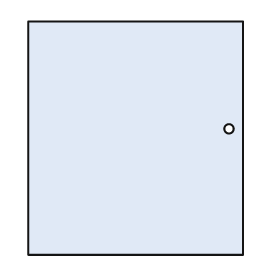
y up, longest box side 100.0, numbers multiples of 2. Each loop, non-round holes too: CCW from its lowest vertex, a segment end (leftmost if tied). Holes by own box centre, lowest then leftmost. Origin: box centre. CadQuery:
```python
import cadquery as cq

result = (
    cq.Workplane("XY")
    .moveTo(-46.0, -50.0)
    .lineTo(46.0, -50.0)
    .lineTo(46.0, 50.0)
    .lineTo(-46.0, 50.0)
    .close()
    .moveTo(40.0, 4.0)
    .circle(2.0)
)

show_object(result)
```